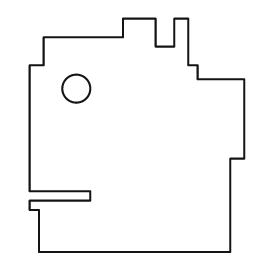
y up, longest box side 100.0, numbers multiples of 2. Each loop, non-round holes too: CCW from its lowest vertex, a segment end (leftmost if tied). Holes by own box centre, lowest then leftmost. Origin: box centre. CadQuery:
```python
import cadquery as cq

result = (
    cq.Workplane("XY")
    .moveTo(-42.0, -50.0)
    .lineTo(40.0, -50.0)
    .lineTo(40.0, -10.0)
    .lineTo(46.0, -10.0)
    .lineTo(46.0, 24.0)
    .lineTo(26.0, 24.0)
    .lineTo(26.0, 30.0)
    .lineTo(22.0, 30.0)
    .lineTo(22.0, 50.0)
    .lineTo(16.0, 50.0)
    .lineTo(16.0, 38.0)
    .lineTo(8.0, 38.0)
    .lineTo(8.0, 50.0)
    .lineTo(-6.0, 50.0)
    .lineTo(-6.0, 42.0)
    .lineTo(-40.0, 42.0)
    .lineTo(-40.0, 30.0)
    .lineTo(-46.0, 30.0)
    .lineTo(-46.0, -24.0)
    .lineTo(-20.0, -24.0)
    .lineTo(-20.0, -28.0)
    .lineTo(-46.0, -28.0)
    .lineTo(-46.0, -32.0)
    .lineTo(-42.0, -32.0)
    .close()
    .moveTo(-26.0, 20.0)
    .circle(6.0)
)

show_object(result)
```